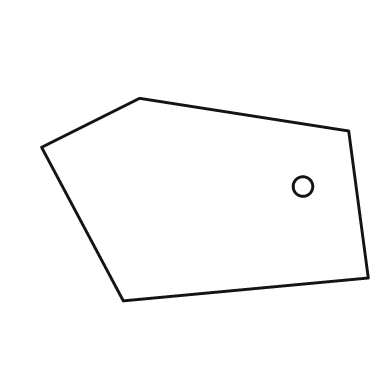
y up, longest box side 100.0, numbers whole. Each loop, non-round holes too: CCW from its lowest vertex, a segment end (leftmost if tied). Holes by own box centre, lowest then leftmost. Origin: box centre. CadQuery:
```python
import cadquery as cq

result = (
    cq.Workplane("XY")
    .moveTo(-25.0, -31.0)
    .lineTo(50.0, -24.0)
    .lineTo(44.0, 21.0)
    .lineTo(-20.0, 31.0)
    .lineTo(-50.0, 16.0)
    .close()
    .moveTo(30.0, 4.0)
    .circle(3.0)
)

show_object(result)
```